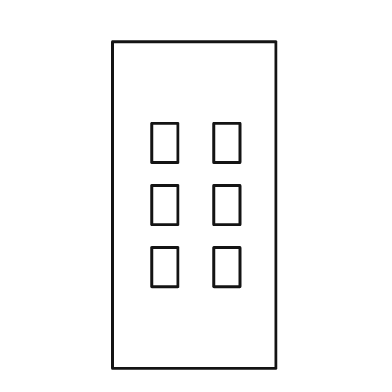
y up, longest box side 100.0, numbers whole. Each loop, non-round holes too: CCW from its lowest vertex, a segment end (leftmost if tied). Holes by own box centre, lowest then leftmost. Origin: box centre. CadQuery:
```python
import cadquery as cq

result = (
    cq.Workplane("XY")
    .moveTo(-25.0, -50.0)
    .lineTo(25.0, -50.0)
    .lineTo(25.0, 50.0)
    .lineTo(-25.0, 50.0)
    .close()
    .moveTo(-13.0, -25.0)
    .lineTo(-5.0, -25.0)
    .lineTo(-5.0, -13.0)
    .lineTo(-13.0, -13.0)
    .close()
    .moveTo(6.0, -25.0)
    .lineTo(14.0, -25.0)
    .lineTo(14.0, -13.0)
    .lineTo(6.0, -13.0)
    .close()
    .moveTo(-13.0, -6.0)
    .lineTo(-5.0, -6.0)
    .lineTo(-5.0, 6.0)
    .lineTo(-13.0, 6.0)
    .close()
    .moveTo(6.0, -6.0)
    .lineTo(14.0, -6.0)
    .lineTo(14.0, 6.0)
    .lineTo(6.0, 6.0)
    .close()
    .moveTo(-13.0, 13.0)
    .lineTo(-5.0, 13.0)
    .lineTo(-5.0, 25.0)
    .lineTo(-13.0, 25.0)
    .close()
    .moveTo(6.0, 13.0)
    .lineTo(14.0, 13.0)
    .lineTo(14.0, 25.0)
    .lineTo(6.0, 25.0)
    .close()
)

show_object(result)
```